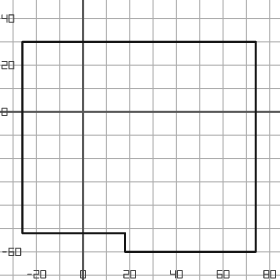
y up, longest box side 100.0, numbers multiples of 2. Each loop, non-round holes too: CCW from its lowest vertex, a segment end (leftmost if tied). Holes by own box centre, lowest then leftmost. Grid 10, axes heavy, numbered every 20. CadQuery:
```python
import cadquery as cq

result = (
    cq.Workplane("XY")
    .moveTo(18.0, -60.0)
    .lineTo(74.0, -60.0)
    .lineTo(74.0, 30.0)
    .lineTo(-26.0, 30.0)
    .lineTo(-26.0, -52.0)
    .lineTo(18.0, -52.0)
    .close()
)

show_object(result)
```